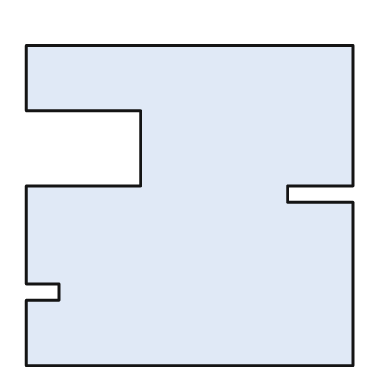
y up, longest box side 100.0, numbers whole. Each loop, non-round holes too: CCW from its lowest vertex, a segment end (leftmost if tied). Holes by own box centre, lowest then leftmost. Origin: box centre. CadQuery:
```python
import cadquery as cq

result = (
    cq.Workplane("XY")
    .moveTo(-50.0, -49.0)
    .lineTo(50.0, -49.0)
    .lineTo(50.0, 1.0)
    .lineTo(30.0, 1.0)
    .lineTo(30.0, 6.0)
    .lineTo(50.0, 6.0)
    .lineTo(50.0, 49.0)
    .lineTo(-50.0, 49.0)
    .lineTo(-50.0, 29.0)
    .lineTo(-15.0, 29.0)
    .lineTo(-15.0, 6.0)
    .lineTo(-50.0, 6.0)
    .lineTo(-50.0, -24.0)
    .lineTo(-40.0, -24.0)
    .lineTo(-40.0, -29.0)
    .lineTo(-50.0, -29.0)
    .close()
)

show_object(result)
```